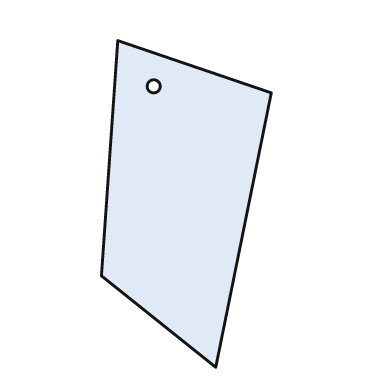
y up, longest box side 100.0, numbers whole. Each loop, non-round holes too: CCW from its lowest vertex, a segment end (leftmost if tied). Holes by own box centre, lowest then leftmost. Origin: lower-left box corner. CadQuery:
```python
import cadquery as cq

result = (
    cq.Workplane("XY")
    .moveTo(35.0, 0.0)
    .lineTo(52.0, 84.0)
    .lineTo(5.0, 100.0)
    .lineTo(0.0, 28.0)
    .close()
    .moveTo(16.0, 86.0)
    .circle(2.0)
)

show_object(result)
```